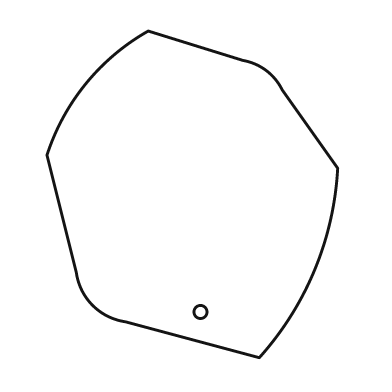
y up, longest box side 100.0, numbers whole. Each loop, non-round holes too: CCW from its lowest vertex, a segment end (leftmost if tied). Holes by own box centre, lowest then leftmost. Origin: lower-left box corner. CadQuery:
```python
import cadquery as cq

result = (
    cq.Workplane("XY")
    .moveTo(65.0, 0.0)
    .threePointArc((82.0, 27.0), (89.0, 58.0))
    .lineTo(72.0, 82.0)
    .threePointArc((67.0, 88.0), (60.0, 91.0))
    .lineTo(31.0, 100.0)
    .threePointArc((12.0, 84.0), (0.0, 62.0))
    .lineTo(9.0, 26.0)
    .threePointArc((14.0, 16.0), (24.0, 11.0))
    .close()
    .moveTo(47.0, 14.0)
    .circle(2.0)
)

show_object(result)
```